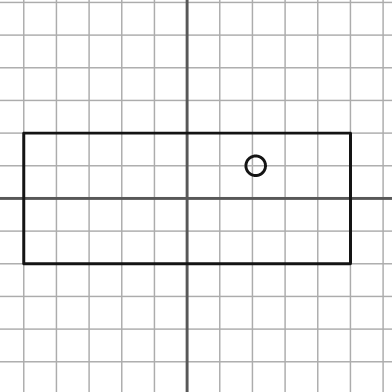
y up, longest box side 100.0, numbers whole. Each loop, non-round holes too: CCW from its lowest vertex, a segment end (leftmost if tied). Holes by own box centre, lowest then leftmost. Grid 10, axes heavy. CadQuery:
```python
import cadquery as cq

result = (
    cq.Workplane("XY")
    .moveTo(-50.0, -20.0)
    .lineTo(50.0, -20.0)
    .lineTo(50.0, 20.0)
    .lineTo(-50.0, 20.0)
    .close()
    .moveTo(21.0, 10.0)
    .circle(3.0)
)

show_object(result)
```